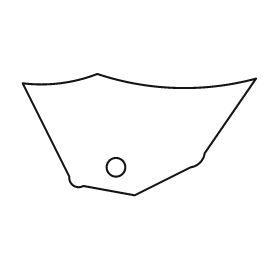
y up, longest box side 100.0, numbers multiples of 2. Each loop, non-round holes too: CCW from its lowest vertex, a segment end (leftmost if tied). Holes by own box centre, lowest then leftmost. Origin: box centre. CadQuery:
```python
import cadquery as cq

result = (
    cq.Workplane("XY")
    .moveTo(-2.0, -26.0)
    .lineTo(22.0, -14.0)
    .threePointArc((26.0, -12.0), (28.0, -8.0))
    .lineTo(50.0, 24.0)
    .threePointArc((16.0, 20.0), (-18.0, 26.0))
    .threePointArc((-34.0, 22.0), (-50.0, 22.0))
    .lineTo(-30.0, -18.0)
    .threePointArc((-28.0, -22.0), (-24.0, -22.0))
    .close()
    .moveTo(-10.0, -14.0)
    .circle(4.0)
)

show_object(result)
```